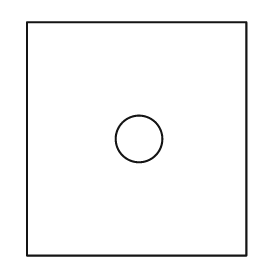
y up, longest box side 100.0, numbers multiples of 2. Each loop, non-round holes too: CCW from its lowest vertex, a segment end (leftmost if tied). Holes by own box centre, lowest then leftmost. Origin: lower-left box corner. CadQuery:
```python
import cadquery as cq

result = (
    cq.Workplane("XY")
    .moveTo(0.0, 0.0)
    .lineTo(94.0, 0.0)
    .lineTo(94.0, 100.0)
    .lineTo(0.0, 100.0)
    .close()
    .moveTo(48.0, 50.0)
    .circle(10.0)
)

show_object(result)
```